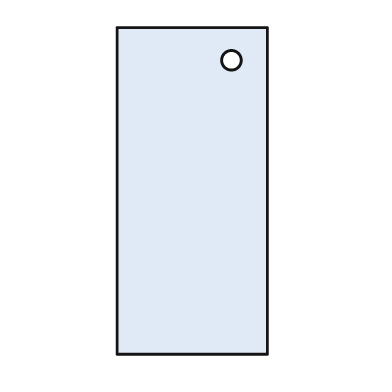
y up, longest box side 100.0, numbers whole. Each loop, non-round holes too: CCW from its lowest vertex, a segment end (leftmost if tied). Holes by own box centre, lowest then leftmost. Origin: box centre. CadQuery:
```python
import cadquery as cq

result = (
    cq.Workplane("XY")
    .moveTo(-23.0, -50.0)
    .lineTo(23.0, -50.0)
    .lineTo(23.0, 50.0)
    .lineTo(-23.0, 50.0)
    .close()
    .moveTo(12.0, 40.0)
    .circle(3.0)
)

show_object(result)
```